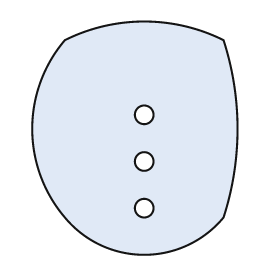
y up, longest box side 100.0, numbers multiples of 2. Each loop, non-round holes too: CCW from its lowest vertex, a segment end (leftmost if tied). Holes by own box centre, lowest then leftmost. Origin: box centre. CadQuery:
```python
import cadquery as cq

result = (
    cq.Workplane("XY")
    .moveTo(-30.0, -34.0)
    .threePointArc((4.0, -50.0), (38.0, -34.0))
    .threePointArc((44.0, 4.0), (38.0, 42.0))
    .threePointArc((4.0, 50.0), (-30.0, 42.0))
    .threePointArc((-44.0, 4.0), (-30.0, -34.0))
    .close()
    .moveTo(4.0, -30.0)
    .circle(4.0)
    .moveTo(4.0, -10.0)
    .circle(4.0)
    .moveTo(4.0, 10.0)
    .circle(4.0)
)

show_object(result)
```